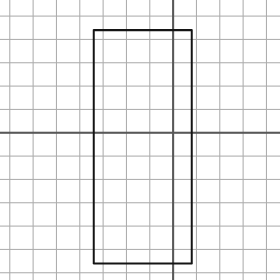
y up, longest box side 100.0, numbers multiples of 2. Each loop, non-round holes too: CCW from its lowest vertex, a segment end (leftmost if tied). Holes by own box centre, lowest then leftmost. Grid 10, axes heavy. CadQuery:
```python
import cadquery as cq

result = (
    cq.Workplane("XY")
    .moveTo(-34.0, -56.0)
    .lineTo(8.0, -56.0)
    .lineTo(8.0, 44.0)
    .lineTo(-34.0, 44.0)
    .close()
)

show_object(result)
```